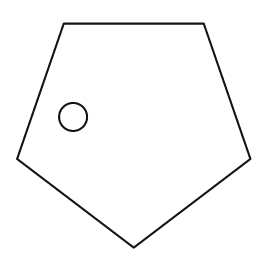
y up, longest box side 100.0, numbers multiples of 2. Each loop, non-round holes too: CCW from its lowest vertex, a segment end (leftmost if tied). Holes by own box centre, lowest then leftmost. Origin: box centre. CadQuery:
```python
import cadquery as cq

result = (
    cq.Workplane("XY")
    .moveTo(0.0, -48.0)
    .lineTo(50.0, -10.0)
    .lineTo(30.0, 48.0)
    .lineTo(-30.0, 48.0)
    .lineTo(-50.0, -10.0)
    .close()
    .moveTo(-26.0, 8.0)
    .circle(6.0)
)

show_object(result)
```